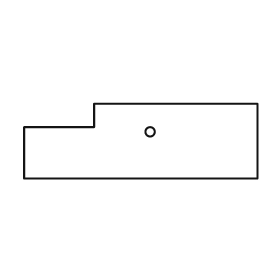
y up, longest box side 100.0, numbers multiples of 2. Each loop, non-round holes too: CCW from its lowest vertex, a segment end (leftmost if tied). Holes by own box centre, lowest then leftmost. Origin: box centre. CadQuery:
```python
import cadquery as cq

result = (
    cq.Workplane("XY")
    .moveTo(-50.0, -16.0)
    .lineTo(50.0, -16.0)
    .lineTo(50.0, 16.0)
    .lineTo(-20.0, 16.0)
    .lineTo(-20.0, 6.0)
    .lineTo(-50.0, 6.0)
    .close()
    .moveTo(4.0, 4.0)
    .circle(2.0)
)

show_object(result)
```